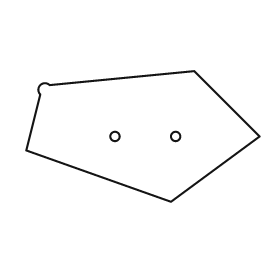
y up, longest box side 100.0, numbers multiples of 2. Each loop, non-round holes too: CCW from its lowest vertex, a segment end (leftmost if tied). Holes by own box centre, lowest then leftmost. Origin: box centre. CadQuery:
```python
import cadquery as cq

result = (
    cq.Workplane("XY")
    .moveTo(12.0, -28.0)
    .lineTo(50.0, 0.0)
    .lineTo(22.0, 28.0)
    .lineTo(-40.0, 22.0)
    .threePointArc((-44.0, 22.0), (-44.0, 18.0))
    .lineTo(-50.0, -6.0)
    .close()
    .moveTo(-12.0, 0.0)
    .circle(2.0)
    .moveTo(14.0, 0.0)
    .circle(2.0)
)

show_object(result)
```